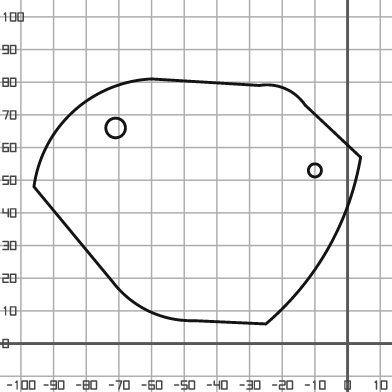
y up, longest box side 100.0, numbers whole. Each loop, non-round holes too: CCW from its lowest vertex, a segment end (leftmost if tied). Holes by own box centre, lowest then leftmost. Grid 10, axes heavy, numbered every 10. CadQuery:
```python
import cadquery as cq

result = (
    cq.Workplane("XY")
    .moveTo(-25.0, 6.0)
    .threePointArc((-6.0, 29.0), (4.0, 57.0))
    .lineTo(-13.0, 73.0)
    .threePointArc((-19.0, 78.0), (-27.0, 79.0))
    .lineTo(-60.0, 81.0)
    .threePointArc((-84.0, 71.0), (-96.0, 48.0))
    .lineTo(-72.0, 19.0)
    .threePointArc((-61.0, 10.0), (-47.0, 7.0))
    .close()
    .moveTo(-10.0, 53.0)
    .circle(2.0)
    .moveTo(-71.0, 66.0)
    .circle(3.0)
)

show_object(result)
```